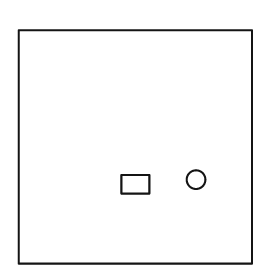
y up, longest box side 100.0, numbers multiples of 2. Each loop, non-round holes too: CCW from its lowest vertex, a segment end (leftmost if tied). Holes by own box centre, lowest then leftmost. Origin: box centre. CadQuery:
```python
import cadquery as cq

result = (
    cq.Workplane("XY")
    .moveTo(-50.0, -50.0)
    .lineTo(50.0, -50.0)
    .lineTo(50.0, 50.0)
    .lineTo(-50.0, 50.0)
    .close()
    .moveTo(-6.0, -20.0)
    .lineTo(6.0, -20.0)
    .lineTo(6.0, -12.0)
    .lineTo(-6.0, -12.0)
    .close()
    .moveTo(26.0, -14.0)
    .circle(4.0)
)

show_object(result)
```